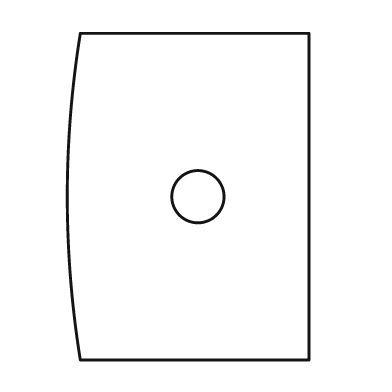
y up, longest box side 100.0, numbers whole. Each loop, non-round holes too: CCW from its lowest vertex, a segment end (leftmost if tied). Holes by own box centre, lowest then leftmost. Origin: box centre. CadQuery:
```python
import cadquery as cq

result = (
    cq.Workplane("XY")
    .moveTo(-33.0, -50.0)
    .lineTo(37.0, -50.0)
    .lineTo(37.0, 50.0)
    .lineTo(-33.0, 50.0)
    .threePointArc((-37.0, 0.0), (-33.0, -50.0))
    .close()
    .moveTo(3.0, 0.0)
    .circle(8.0)
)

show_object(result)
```